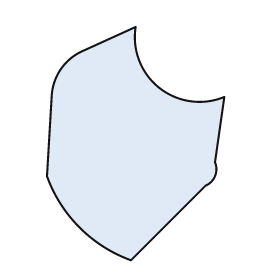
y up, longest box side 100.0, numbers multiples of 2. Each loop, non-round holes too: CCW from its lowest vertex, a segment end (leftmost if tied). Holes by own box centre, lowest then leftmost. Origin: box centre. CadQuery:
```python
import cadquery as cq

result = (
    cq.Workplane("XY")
    .moveTo(-2.0, -50.0)
    .lineTo(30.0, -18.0)
    .threePointArc((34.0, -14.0), (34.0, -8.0))
    .lineTo(38.0, 20.0)
    .threePointArc((10.0, 24.0), (0.0, 50.0))
    .lineTo(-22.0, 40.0)
    .threePointArc((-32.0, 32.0), (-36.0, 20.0))
    .lineTo(-38.0, -14.0)
    .threePointArc((-24.0, -36.0), (-2.0, -50.0))
    .close()
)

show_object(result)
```